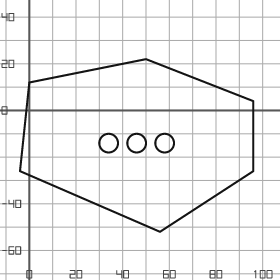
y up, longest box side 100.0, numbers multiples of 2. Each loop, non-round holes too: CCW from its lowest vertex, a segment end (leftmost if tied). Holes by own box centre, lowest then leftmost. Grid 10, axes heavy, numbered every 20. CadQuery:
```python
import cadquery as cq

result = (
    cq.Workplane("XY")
    .moveTo(56.0, -52.0)
    .lineTo(96.0, -26.0)
    .lineTo(96.0, 4.0)
    .lineTo(50.0, 22.0)
    .lineTo(0.0, 12.0)
    .lineTo(-4.0, -26.0)
    .close()
    .moveTo(34.0, -14.0)
    .circle(4.0)
    .moveTo(46.0, -14.0)
    .circle(4.0)
    .moveTo(58.0, -14.0)
    .circle(4.0)
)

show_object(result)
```